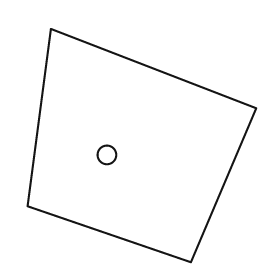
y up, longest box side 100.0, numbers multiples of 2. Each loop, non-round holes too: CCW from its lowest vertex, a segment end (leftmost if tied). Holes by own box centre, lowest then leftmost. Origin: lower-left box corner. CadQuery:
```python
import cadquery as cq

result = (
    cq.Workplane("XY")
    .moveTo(70.0, 0.0)
    .lineTo(98.0, 66.0)
    .lineTo(10.0, 100.0)
    .lineTo(0.0, 24.0)
    .close()
    .moveTo(34.0, 46.0)
    .circle(4.0)
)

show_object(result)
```